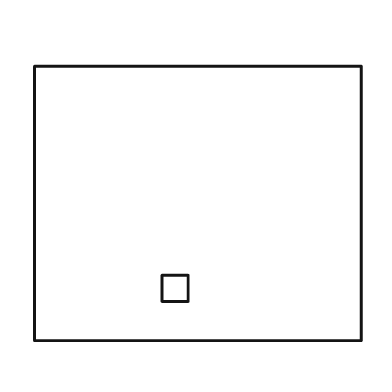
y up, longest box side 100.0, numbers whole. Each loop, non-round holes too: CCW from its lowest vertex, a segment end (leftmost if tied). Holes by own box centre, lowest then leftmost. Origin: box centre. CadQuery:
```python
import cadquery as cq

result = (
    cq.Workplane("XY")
    .moveTo(-50.0, -42.0)
    .lineTo(50.0, -42.0)
    .lineTo(50.0, 42.0)
    .lineTo(-50.0, 42.0)
    .close()
    .moveTo(-11.0, -30.0)
    .lineTo(-3.0, -30.0)
    .lineTo(-3.0, -22.0)
    .lineTo(-11.0, -22.0)
    .close()
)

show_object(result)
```